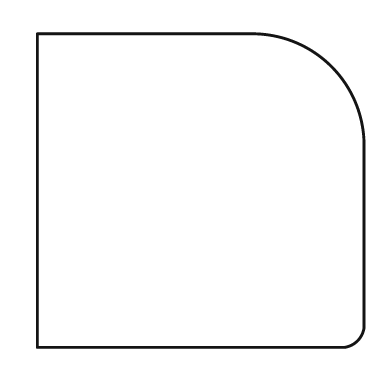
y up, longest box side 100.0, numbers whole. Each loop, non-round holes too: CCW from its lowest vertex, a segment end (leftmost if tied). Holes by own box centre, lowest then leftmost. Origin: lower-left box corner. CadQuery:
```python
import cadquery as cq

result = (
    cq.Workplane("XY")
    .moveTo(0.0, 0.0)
    .lineTo(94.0, 0.0)
    .threePointArc((98.0, 2.0), (100.0, 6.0))
    .lineTo(100.0, 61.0)
    .threePointArc((90.0, 86.0), (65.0, 96.0))
    .lineTo(0.0, 96.0)
    .close()
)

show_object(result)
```